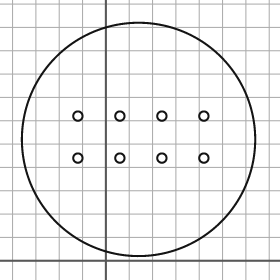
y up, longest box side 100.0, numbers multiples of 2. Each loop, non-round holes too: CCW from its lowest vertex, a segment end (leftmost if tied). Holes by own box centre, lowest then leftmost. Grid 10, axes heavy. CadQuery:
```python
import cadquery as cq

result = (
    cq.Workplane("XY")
    .moveTo(14.0, 52.0)
    .circle(50.0)
    .moveTo(-12.0, 44.0)
    .circle(2.0)
    .moveTo(6.0, 44.0)
    .circle(2.0)
    .moveTo(24.0, 44.0)
    .circle(2.0)
    .moveTo(42.0, 44.0)
    .circle(2.0)
    .moveTo(-12.0, 62.0)
    .circle(2.0)
    .moveTo(6.0, 62.0)
    .circle(2.0)
    .moveTo(24.0, 62.0)
    .circle(2.0)
    .moveTo(42.0, 62.0)
    .circle(2.0)
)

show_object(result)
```